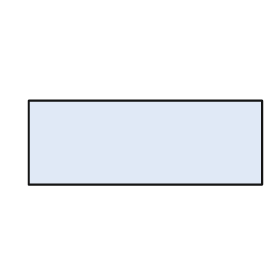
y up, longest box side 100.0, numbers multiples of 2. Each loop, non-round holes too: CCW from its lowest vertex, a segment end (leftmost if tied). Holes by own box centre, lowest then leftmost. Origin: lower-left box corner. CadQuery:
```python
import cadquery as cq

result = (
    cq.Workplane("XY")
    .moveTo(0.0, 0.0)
    .lineTo(100.0, 0.0)
    .lineTo(100.0, 36.0)
    .lineTo(0.0, 36.0)
    .close()
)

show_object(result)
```